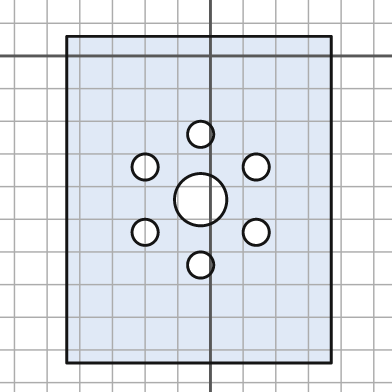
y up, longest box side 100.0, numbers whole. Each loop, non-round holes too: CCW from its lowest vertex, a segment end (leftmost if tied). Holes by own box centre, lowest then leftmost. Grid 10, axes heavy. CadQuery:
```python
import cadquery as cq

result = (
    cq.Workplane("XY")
    .moveTo(-44.0, -94.0)
    .lineTo(37.0, -94.0)
    .lineTo(37.0, 6.0)
    .lineTo(-44.0, 6.0)
    .close()
    .moveTo(-3.0, -64.0)
    .circle(4.0)
    .moveTo(-20.0, -54.0)
    .circle(4.0)
    .moveTo(14.0, -54.0)
    .circle(4.0)
    .moveTo(-3.0, -44.0)
    .circle(8.0)
    .moveTo(-20.0, -34.0)
    .circle(4.0)
    .moveTo(14.0, -34.0)
    .circle(4.0)
    .moveTo(-3.0, -24.0)
    .circle(4.0)
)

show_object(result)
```